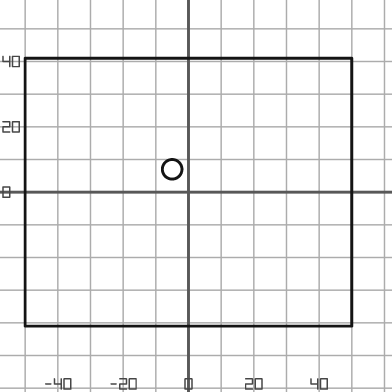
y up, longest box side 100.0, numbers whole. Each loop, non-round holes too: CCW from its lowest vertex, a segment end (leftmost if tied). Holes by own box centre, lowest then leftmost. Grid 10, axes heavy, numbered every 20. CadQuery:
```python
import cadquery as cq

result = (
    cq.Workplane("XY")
    .moveTo(-50.0, -41.0)
    .lineTo(50.0, -41.0)
    .lineTo(50.0, 41.0)
    .lineTo(-50.0, 41.0)
    .close()
    .moveTo(-5.0, 7.0)
    .circle(3.0)
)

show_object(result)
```